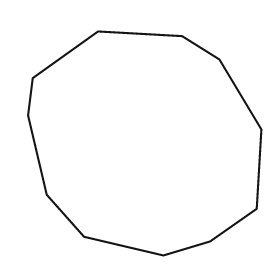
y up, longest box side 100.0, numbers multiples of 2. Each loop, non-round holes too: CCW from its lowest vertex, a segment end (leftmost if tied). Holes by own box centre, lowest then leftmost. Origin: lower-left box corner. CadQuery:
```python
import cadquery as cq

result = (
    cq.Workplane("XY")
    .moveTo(58.0, 0.0)
    .lineTo(78.0, 6.0)
    .lineTo(98.0, 20.0)
    .lineTo(100.0, 54.0)
    .lineTo(82.0, 84.0)
    .lineTo(66.0, 94.0)
    .lineTo(30.0, 96.0)
    .lineTo(2.0, 76.0)
    .lineTo(0.0, 60.0)
    .lineTo(8.0, 26.0)
    .lineTo(24.0, 8.0)
    .close()
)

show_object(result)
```